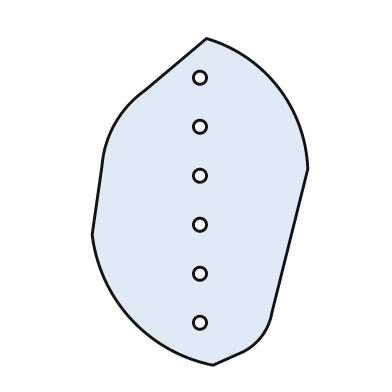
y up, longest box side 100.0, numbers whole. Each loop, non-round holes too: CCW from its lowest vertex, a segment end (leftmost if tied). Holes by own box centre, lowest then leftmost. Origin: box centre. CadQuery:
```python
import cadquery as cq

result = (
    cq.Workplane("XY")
    .moveTo(4.0, -50.0)
    .lineTo(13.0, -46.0)
    .threePointArc((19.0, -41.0), (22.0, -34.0))
    .lineTo(33.0, 10.0)
    .threePointArc((24.0, 35.0), (2.0, 50.0))
    .lineTo(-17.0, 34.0)
    .threePointArc((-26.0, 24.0), (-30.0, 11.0))
    .lineTo(-33.0, -10.0)
    .threePointArc((-21.0, -36.0), (4.0, -50.0))
    .close()
    .moveTo(0.0, -37.0)
    .circle(2.0)
    .moveTo(0.0, -22.0)
    .circle(2.0)
    .moveTo(0.0, -7.0)
    .circle(2.0)
    .moveTo(0.0, 8.0)
    .circle(2.0)
    .moveTo(0.0, 23.0)
    .circle(2.0)
    .moveTo(0.0, 38.0)
    .circle(2.0)
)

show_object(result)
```